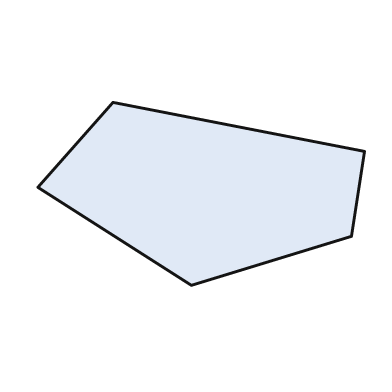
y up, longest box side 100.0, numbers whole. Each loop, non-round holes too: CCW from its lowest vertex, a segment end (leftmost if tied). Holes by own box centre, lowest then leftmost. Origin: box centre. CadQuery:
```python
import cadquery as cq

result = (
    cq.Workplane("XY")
    .moveTo(-3.0, -28.0)
    .lineTo(46.0, -13.0)
    .lineTo(50.0, 13.0)
    .lineTo(-27.0, 28.0)
    .lineTo(-50.0, 2.0)
    .close()
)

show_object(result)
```